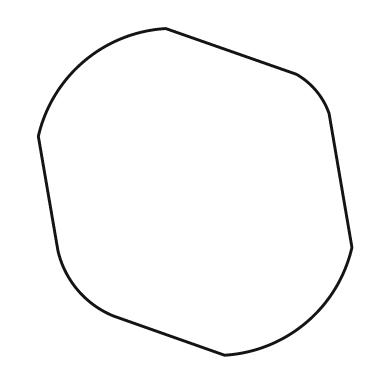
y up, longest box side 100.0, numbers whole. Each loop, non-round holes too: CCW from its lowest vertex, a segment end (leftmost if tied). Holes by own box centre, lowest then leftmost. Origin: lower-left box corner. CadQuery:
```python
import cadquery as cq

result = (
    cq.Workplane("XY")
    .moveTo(57.0, 0.0)
    .threePointArc((82.0, 10.0), (96.0, 33.0))
    .lineTo(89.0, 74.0)
    .threePointArc((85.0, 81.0), (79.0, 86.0))
    .lineTo(39.0, 100.0)
    .threePointArc((14.0, 90.0), (0.0, 67.0))
    .lineTo(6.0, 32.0)
    .threePointArc((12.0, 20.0), (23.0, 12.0))
    .close()
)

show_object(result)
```